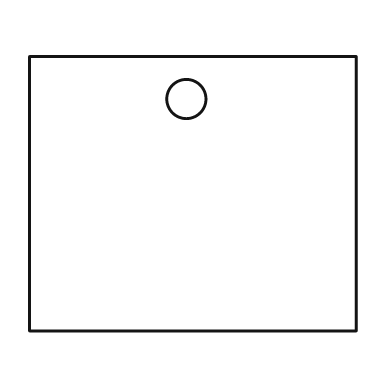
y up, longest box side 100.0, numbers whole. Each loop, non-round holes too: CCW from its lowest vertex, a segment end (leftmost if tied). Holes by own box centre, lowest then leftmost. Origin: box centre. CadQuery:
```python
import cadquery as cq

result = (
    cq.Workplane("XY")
    .moveTo(-50.0, -42.0)
    .lineTo(50.0, -42.0)
    .lineTo(50.0, 42.0)
    .lineTo(-50.0, 42.0)
    .close()
    .moveTo(-2.0, 29.0)
    .circle(6.0)
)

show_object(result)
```